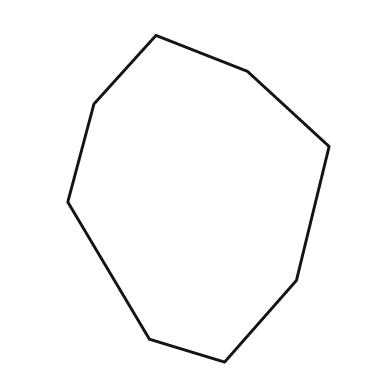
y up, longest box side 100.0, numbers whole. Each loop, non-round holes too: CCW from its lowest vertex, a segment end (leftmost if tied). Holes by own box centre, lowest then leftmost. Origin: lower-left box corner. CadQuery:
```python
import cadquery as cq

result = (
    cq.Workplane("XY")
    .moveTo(48.0, 0.0)
    .lineTo(70.0, 25.0)
    .lineTo(80.0, 66.0)
    .lineTo(55.0, 89.0)
    .lineTo(27.0, 100.0)
    .lineTo(8.0, 79.0)
    .lineTo(0.0, 49.0)
    .lineTo(25.0, 7.0)
    .close()
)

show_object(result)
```